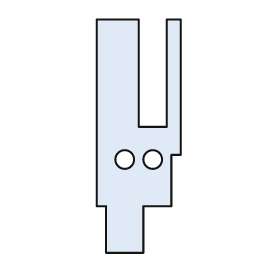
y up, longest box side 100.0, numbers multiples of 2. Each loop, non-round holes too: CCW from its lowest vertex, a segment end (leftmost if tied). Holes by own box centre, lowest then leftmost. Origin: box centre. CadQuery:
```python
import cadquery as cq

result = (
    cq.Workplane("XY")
    .moveTo(-14.0, -50.0)
    .lineTo(2.0, -50.0)
    .lineTo(2.0, -30.0)
    .lineTo(14.0, -30.0)
    .lineTo(14.0, -8.0)
    .lineTo(18.0, -8.0)
    .lineTo(18.0, 50.0)
    .lineTo(12.0, 50.0)
    .lineTo(12.0, 4.0)
    .lineTo(0.0, 4.0)
    .lineTo(0.0, 50.0)
    .lineTo(-18.0, 50.0)
    .lineTo(-18.0, -30.0)
    .lineTo(-14.0, -30.0)
    .close()
    .moveTo(-6.0, -10.0)
    .circle(4.0)
    .moveTo(6.0, -10.0)
    .circle(4.0)
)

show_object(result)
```